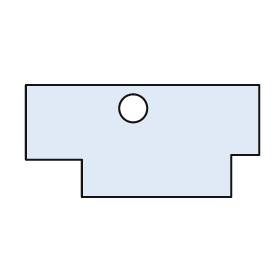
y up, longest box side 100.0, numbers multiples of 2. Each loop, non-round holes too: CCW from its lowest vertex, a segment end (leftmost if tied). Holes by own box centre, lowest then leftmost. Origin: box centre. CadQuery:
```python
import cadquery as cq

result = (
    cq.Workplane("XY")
    .moveTo(-26.0, -24.0)
    .lineTo(38.0, -24.0)
    .lineTo(38.0, -6.0)
    .lineTo(50.0, -6.0)
    .lineTo(50.0, 24.0)
    .lineTo(-50.0, 24.0)
    .lineTo(-50.0, -8.0)
    .lineTo(-26.0, -8.0)
    .close()
    .moveTo(-4.0, 14.0)
    .circle(6.0)
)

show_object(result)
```